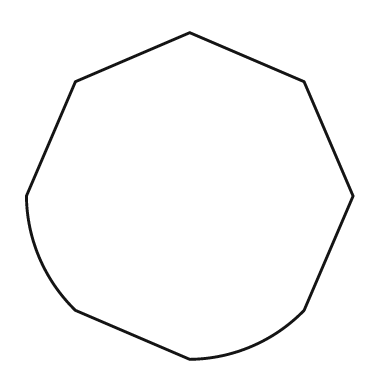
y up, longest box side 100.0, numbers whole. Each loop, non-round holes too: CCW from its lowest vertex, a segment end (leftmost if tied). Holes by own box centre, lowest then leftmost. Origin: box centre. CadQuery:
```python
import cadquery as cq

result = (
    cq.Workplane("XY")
    .moveTo(0.0, -50.0)
    .threePointArc((19.0, -46.0), (35.0, -35.0))
    .lineTo(50.0, 0.0)
    .lineTo(35.0, 35.0)
    .lineTo(0.0, 50.0)
    .lineTo(-35.0, 35.0)
    .lineTo(-50.0, 0.0)
    .threePointArc((-46.0, -19.0), (-35.0, -35.0))
    .close()
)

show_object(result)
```